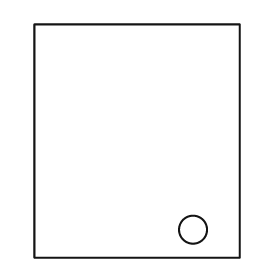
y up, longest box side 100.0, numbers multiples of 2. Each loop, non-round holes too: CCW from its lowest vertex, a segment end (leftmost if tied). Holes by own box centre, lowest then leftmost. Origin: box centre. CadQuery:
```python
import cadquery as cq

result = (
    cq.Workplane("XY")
    .moveTo(-44.0, -50.0)
    .lineTo(44.0, -50.0)
    .lineTo(44.0, 50.0)
    .lineTo(-44.0, 50.0)
    .close()
    .moveTo(24.0, -38.0)
    .circle(6.0)
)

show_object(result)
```